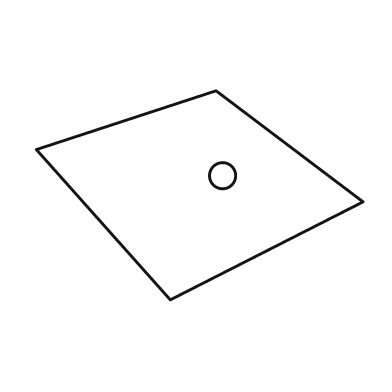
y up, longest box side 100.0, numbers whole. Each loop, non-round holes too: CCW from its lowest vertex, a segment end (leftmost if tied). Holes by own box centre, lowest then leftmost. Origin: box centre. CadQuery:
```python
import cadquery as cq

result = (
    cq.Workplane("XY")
    .moveTo(-9.0, -32.0)
    .lineTo(50.0, -2.0)
    .lineTo(5.0, 32.0)
    .lineTo(-50.0, 14.0)
    .close()
    .moveTo(7.0, 6.0)
    .circle(4.0)
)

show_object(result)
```